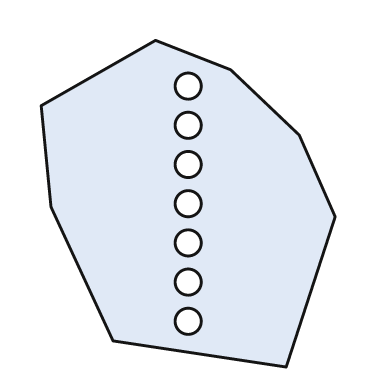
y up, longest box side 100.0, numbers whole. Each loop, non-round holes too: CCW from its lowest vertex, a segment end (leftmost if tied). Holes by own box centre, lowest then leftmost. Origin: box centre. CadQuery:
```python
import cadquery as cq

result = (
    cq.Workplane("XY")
    .moveTo(30.0, -50.0)
    .lineTo(45.0, -4.0)
    .lineTo(34.0, 21.0)
    .lineTo(13.0, 41.0)
    .lineTo(-10.0, 50.0)
    .lineTo(-45.0, 30.0)
    .lineTo(-42.0, -1.0)
    .lineTo(-23.0, -42.0)
    .close()
    .moveTo(0.0, -36.0)
    .circle(4.0)
    .moveTo(0.0, -24.0)
    .circle(4.0)
    .moveTo(0.0, -12.0)
    .circle(4.0)
    .moveTo(0.0, 0.0)
    .circle(4.0)
    .moveTo(0.0, 12.0)
    .circle(4.0)
    .moveTo(0.0, 24.0)
    .circle(4.0)
    .moveTo(0.0, 36.0)
    .circle(4.0)
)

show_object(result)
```